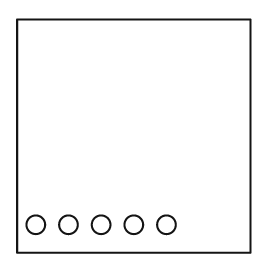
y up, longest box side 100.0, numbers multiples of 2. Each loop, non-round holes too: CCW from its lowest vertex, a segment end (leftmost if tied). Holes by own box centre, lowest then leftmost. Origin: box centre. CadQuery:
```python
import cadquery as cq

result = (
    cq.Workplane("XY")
    .moveTo(-50.0, -50.0)
    .lineTo(50.0, -50.0)
    .lineTo(50.0, 50.0)
    .lineTo(-50.0, 50.0)
    .close()
    .moveTo(-42.0, -38.0)
    .circle(4.0)
    .moveTo(-28.0, -38.0)
    .circle(4.0)
    .moveTo(-14.0, -38.0)
    .circle(4.0)
    .moveTo(0.0, -38.0)
    .circle(4.0)
    .moveTo(14.0, -38.0)
    .circle(4.0)
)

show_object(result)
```